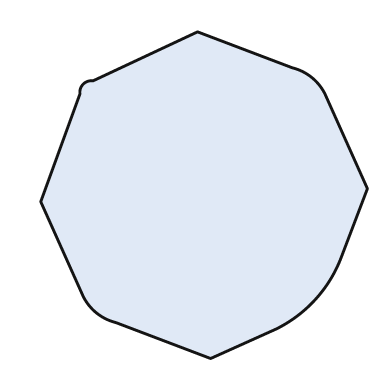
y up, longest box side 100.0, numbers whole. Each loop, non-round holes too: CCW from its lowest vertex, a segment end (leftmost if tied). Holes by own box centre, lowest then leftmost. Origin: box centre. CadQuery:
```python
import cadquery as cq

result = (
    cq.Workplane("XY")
    .moveTo(2.0, -50.0)
    .lineTo(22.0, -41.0)
    .threePointArc((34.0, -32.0), (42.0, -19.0))
    .lineTo(50.0, 2.0)
    .lineTo(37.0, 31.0)
    .threePointArc((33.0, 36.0), (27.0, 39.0))
    .lineTo(-2.0, 50.0)
    .lineTo(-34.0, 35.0)
    .threePointArc((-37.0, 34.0), (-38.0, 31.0))
    .lineTo(-50.0, -2.0)
    .lineTo(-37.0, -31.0)
    .threePointArc((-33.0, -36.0), (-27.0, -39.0))
    .close()
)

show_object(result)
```